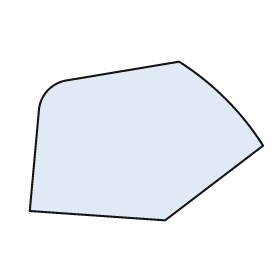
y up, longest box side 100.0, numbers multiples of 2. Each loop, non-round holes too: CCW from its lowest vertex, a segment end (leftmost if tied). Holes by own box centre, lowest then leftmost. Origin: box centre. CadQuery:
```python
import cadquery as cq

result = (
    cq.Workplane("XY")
    .moveTo(8.0, -34.0)
    .lineTo(50.0, -2.0)
    .threePointArc((34.0, 18.0), (14.0, 34.0))
    .lineTo(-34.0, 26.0)
    .threePointArc((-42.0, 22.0), (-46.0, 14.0))
    .lineTo(-50.0, -30.0)
    .close()
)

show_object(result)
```